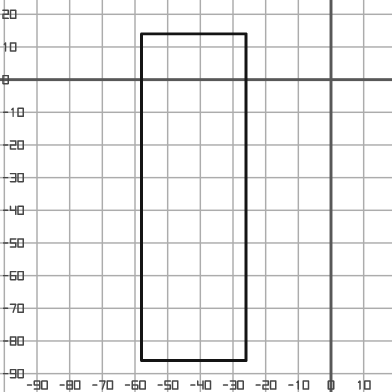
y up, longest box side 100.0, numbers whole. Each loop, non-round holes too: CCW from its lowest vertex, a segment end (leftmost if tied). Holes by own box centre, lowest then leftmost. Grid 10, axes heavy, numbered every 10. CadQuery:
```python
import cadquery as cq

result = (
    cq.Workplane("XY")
    .moveTo(-58.0, -86.0)
    .lineTo(-26.0, -86.0)
    .lineTo(-26.0, 14.0)
    .lineTo(-58.0, 14.0)
    .close()
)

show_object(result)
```